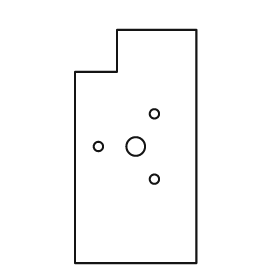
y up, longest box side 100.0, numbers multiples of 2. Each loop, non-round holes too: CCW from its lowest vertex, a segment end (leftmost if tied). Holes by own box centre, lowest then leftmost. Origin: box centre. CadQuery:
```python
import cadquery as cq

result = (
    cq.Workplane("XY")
    .moveTo(-26.0, -50.0)
    .lineTo(26.0, -50.0)
    .lineTo(26.0, 50.0)
    .lineTo(-8.0, 50.0)
    .lineTo(-8.0, 32.0)
    .lineTo(-26.0, 32.0)
    .close()
    .moveTo(8.0, -14.0)
    .circle(2.0)
    .moveTo(-16.0, 0.0)
    .circle(2.0)
    .moveTo(0.0, 0.0)
    .circle(4.0)
    .moveTo(8.0, 14.0)
    .circle(2.0)
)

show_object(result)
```